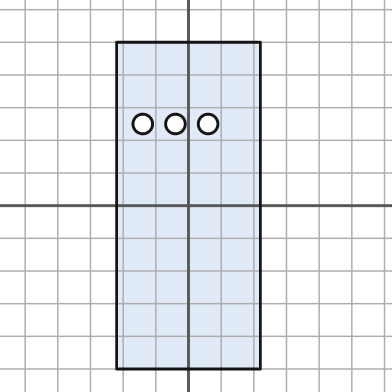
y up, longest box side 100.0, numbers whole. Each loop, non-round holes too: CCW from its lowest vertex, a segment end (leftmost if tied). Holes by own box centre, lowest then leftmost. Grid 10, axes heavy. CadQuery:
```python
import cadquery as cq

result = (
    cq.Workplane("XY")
    .moveTo(-22.0, -50.0)
    .lineTo(22.0, -50.0)
    .lineTo(22.0, 50.0)
    .lineTo(-22.0, 50.0)
    .close()
    .moveTo(-14.0, 25.0)
    .circle(3.0)
    .moveTo(-4.0, 25.0)
    .circle(3.0)
    .moveTo(6.0, 25.0)
    .circle(3.0)
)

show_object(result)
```